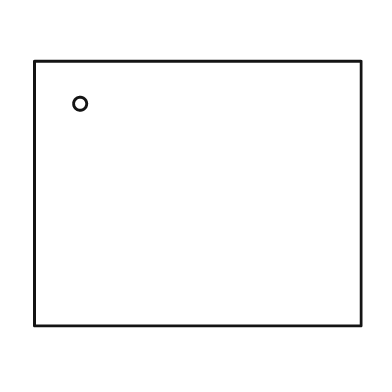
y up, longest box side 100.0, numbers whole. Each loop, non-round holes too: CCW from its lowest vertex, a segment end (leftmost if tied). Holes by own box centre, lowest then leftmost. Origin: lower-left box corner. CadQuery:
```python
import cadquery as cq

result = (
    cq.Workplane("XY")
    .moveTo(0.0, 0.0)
    .lineTo(100.0, 0.0)
    .lineTo(100.0, 81.0)
    .lineTo(0.0, 81.0)
    .close()
    .moveTo(14.0, 68.0)
    .circle(2.0)
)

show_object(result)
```